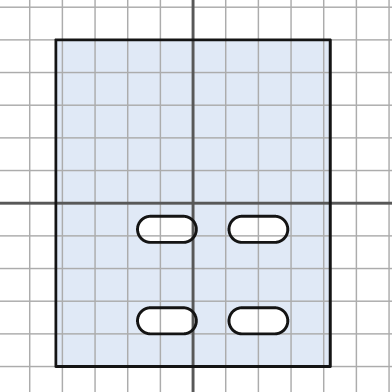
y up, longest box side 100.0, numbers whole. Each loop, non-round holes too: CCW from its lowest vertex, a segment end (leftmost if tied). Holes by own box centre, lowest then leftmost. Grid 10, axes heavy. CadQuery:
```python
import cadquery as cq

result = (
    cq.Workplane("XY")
    .moveTo(-42.0, -50.0)
    .lineTo(42.0, -50.0)
    .lineTo(42.0, 50.0)
    .lineTo(-42.0, 50.0)
    .close()
    .moveTo(-13.0, -40.0)
    .lineTo(-3.0, -40.0)
    .threePointArc((1.0, -36.0), (-3.0, -32.0))
    .lineTo(-13.0, -32.0)
    .threePointArc((-17.0, -36.0), (-13.0, -40.0))
    .close()
    .moveTo(15.0, -40.0)
    .lineTo(25.0, -40.0)
    .threePointArc((29.0, -36.0), (25.0, -32.0))
    .lineTo(15.0, -32.0)
    .threePointArc((11.0, -36.0), (15.0, -40.0))
    .close()
    .moveTo(-13.0, -12.0)
    .lineTo(-3.0, -12.0)
    .threePointArc((1.0, -8.0), (-3.0, -4.0))
    .lineTo(-13.0, -4.0)
    .threePointArc((-17.0, -8.0), (-13.0, -12.0))
    .close()
    .moveTo(15.0, -12.0)
    .lineTo(25.0, -12.0)
    .threePointArc((29.0, -8.0), (25.0, -4.0))
    .lineTo(15.0, -4.0)
    .threePointArc((11.0, -8.0), (15.0, -12.0))
    .close()
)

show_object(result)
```